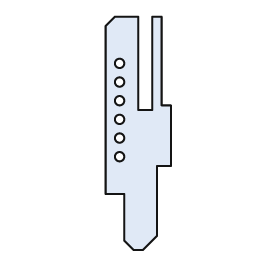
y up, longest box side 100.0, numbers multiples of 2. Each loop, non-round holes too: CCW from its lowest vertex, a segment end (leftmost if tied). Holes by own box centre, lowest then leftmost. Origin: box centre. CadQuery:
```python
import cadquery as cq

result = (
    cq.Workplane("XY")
    .moveTo(-2.0, -50.0)
    .lineTo(2.0, -50.0)
    .lineTo(8.0, -44.0)
    .lineTo(8.0, -14.0)
    .lineTo(14.0, -14.0)
    .lineTo(14.0, 12.0)
    .lineTo(10.0, 12.0)
    .lineTo(10.0, 50.0)
    .lineTo(6.0, 50.0)
    .lineTo(6.0, 10.0)
    .lineTo(0.0, 10.0)
    .lineTo(0.0, 50.0)
    .lineTo(-10.0, 50.0)
    .lineTo(-14.0, 46.0)
    .lineTo(-14.0, -26.0)
    .lineTo(-6.0, -26.0)
    .lineTo(-6.0, -46.0)
    .close()
    .moveTo(-8.0, -10.0)
    .circle(2.0)
    .moveTo(-8.0, -2.0)
    .circle(2.0)
    .moveTo(-8.0, 6.0)
    .circle(2.0)
    .moveTo(-8.0, 14.0)
    .circle(2.0)
    .moveTo(-8.0, 22.0)
    .circle(2.0)
    .moveTo(-8.0, 30.0)
    .circle(2.0)
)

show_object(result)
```